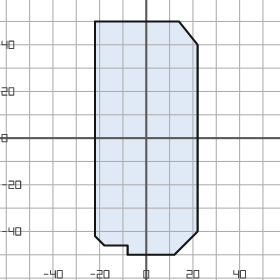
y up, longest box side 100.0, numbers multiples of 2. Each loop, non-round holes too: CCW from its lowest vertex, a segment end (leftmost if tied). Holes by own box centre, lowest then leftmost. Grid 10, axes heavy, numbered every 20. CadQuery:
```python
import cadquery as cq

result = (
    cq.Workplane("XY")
    .moveTo(-8.0, -50.0)
    .lineTo(12.0, -50.0)
    .lineTo(22.0, -40.0)
    .lineTo(22.0, 40.0)
    .lineTo(14.0, 50.0)
    .lineTo(-22.0, 50.0)
    .lineTo(-22.0, -42.0)
    .lineTo(-18.0, -46.0)
    .lineTo(-8.0, -46.0)
    .close()
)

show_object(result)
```